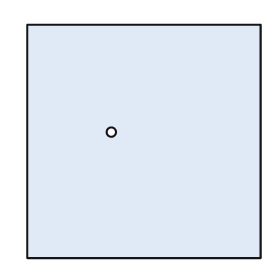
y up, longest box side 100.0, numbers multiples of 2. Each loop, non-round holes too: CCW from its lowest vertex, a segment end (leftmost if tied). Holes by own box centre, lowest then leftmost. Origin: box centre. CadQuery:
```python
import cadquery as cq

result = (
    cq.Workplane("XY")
    .moveTo(-50.0, -50.0)
    .lineTo(50.0, -50.0)
    .lineTo(50.0, 50.0)
    .lineTo(-50.0, 50.0)
    .close()
    .moveTo(-14.0, 4.0)
    .circle(2.0)
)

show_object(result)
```